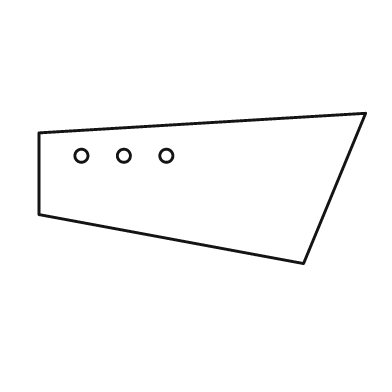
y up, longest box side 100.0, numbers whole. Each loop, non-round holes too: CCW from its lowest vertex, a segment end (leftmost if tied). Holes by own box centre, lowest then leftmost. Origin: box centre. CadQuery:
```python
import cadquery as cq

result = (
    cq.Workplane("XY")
    .moveTo(31.0, -23.0)
    .lineTo(50.0, 23.0)
    .lineTo(-50.0, 17.0)
    .lineTo(-50.0, -8.0)
    .close()
    .moveTo(-37.0, 10.0)
    .circle(2.0)
    .moveTo(-24.0, 10.0)
    .circle(2.0)
    .moveTo(-11.0, 10.0)
    .circle(2.0)
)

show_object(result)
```